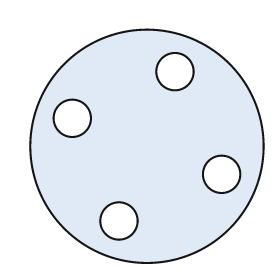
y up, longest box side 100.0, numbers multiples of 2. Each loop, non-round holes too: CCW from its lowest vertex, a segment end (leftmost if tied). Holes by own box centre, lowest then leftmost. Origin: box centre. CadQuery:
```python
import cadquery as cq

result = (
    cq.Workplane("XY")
    .moveTo(0.0, 0.0)
    .circle(50.0)
    .moveTo(-12.0, -32.0)
    .circle(8.0)
    .moveTo(32.0, -12.0)
    .circle(8.0)
    .moveTo(-32.0, 12.0)
    .circle(8.0)
    .moveTo(12.0, 32.0)
    .circle(8.0)
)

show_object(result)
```